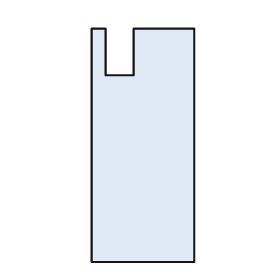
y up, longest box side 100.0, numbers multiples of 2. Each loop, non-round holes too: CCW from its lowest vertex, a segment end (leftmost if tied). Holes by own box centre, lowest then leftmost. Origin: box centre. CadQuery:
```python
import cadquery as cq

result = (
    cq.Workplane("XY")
    .moveTo(-22.0, -50.0)
    .lineTo(22.0, -50.0)
    .lineTo(22.0, 50.0)
    .lineTo(-4.0, 50.0)
    .lineTo(-4.0, 30.0)
    .lineTo(-16.0, 30.0)
    .lineTo(-16.0, 50.0)
    .lineTo(-22.0, 50.0)
    .close()
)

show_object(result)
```